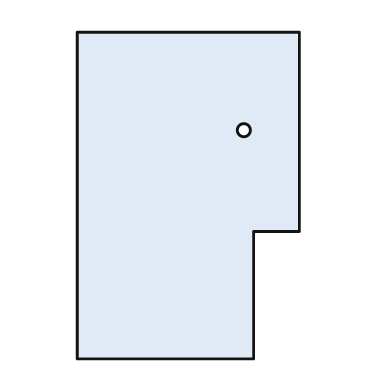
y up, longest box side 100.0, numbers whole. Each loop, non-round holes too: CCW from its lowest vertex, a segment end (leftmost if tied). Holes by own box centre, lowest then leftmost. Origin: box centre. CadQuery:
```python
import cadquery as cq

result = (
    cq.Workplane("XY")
    .moveTo(-34.0, -50.0)
    .lineTo(20.0, -50.0)
    .lineTo(20.0, -11.0)
    .lineTo(34.0, -11.0)
    .lineTo(34.0, 50.0)
    .lineTo(-34.0, 50.0)
    .close()
    .moveTo(17.0, 20.0)
    .circle(2.0)
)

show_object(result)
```